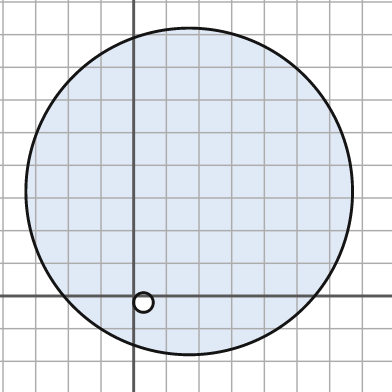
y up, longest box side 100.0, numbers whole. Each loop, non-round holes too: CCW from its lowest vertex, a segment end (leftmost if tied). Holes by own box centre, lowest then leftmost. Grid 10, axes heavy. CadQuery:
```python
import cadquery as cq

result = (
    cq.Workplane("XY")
    .moveTo(17.0, 32.0)
    .circle(50.0)
    .moveTo(3.0, -2.0)
    .circle(3.0)
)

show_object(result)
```